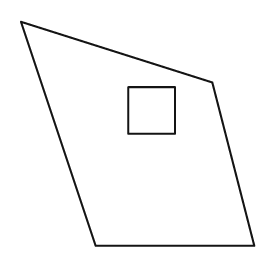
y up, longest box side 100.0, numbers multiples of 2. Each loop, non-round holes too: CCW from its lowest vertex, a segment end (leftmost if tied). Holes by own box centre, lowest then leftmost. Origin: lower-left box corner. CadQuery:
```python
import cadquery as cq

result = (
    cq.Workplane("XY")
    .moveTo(32.0, 0.0)
    .lineTo(100.0, 0.0)
    .lineTo(82.0, 70.0)
    .lineTo(0.0, 96.0)
    .close()
    .moveTo(46.0, 48.0)
    .lineTo(66.0, 48.0)
    .lineTo(66.0, 68.0)
    .lineTo(46.0, 68.0)
    .close()
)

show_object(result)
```